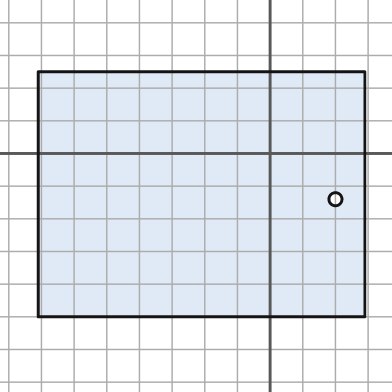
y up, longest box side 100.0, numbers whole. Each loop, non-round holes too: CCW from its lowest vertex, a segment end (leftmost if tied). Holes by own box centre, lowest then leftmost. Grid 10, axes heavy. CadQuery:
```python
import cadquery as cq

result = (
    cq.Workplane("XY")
    .moveTo(-71.0, -50.0)
    .lineTo(29.0, -50.0)
    .lineTo(29.0, 25.0)
    .lineTo(-71.0, 25.0)
    .close()
    .moveTo(20.0, -14.0)
    .circle(2.0)
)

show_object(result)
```